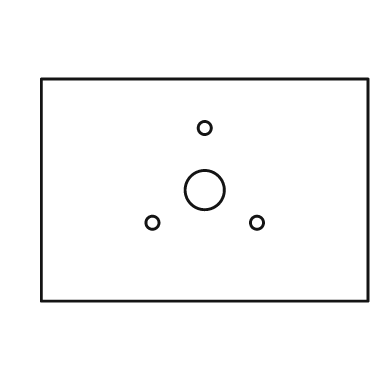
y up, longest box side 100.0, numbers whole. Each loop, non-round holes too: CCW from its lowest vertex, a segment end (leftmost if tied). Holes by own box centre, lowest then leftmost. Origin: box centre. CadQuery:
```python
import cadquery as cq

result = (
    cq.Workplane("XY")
    .moveTo(-50.0, -34.0)
    .lineTo(50.0, -34.0)
    .lineTo(50.0, 34.0)
    .lineTo(-50.0, 34.0)
    .close()
    .moveTo(-16.0, -10.0)
    .circle(2.0)
    .moveTo(16.0, -10.0)
    .circle(2.0)
    .moveTo(0.0, 0.0)
    .circle(6.0)
    .moveTo(0.0, 19.0)
    .circle(2.0)
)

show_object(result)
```